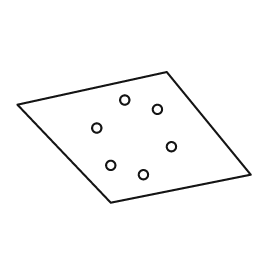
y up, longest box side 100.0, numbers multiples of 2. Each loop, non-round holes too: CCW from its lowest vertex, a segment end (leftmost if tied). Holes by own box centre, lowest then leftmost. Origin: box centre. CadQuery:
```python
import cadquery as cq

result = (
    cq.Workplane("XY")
    .moveTo(-10.0, -28.0)
    .lineTo(50.0, -16.0)
    .lineTo(14.0, 28.0)
    .lineTo(-50.0, 14.0)
    .close()
    .moveTo(4.0, -16.0)
    .circle(2.0)
    .moveTo(-10.0, -12.0)
    .circle(2.0)
    .moveTo(16.0, -4.0)
    .circle(2.0)
    .moveTo(-16.0, 4.0)
    .circle(2.0)
    .moveTo(10.0, 12.0)
    .circle(2.0)
    .moveTo(-4.0, 16.0)
    .circle(2.0)
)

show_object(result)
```